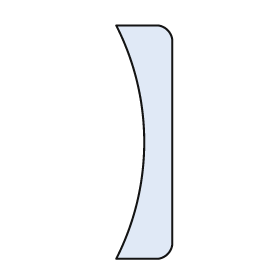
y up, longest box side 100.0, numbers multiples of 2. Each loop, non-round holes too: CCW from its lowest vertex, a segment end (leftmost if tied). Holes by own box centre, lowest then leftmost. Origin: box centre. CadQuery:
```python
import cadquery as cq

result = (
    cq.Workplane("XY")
    .moveTo(-12.0, -50.0)
    .lineTo(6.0, -50.0)
    .threePointArc((10.0, -48.0), (12.0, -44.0))
    .lineTo(12.0, 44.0)
    .threePointArc((10.0, 48.0), (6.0, 50.0))
    .lineTo(-12.0, 50.0)
    .threePointArc((0.0, 0.0), (-12.0, -50.0))
    .close()
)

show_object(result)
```